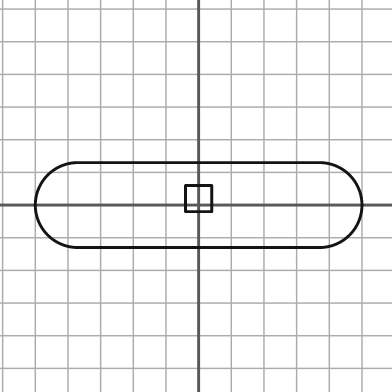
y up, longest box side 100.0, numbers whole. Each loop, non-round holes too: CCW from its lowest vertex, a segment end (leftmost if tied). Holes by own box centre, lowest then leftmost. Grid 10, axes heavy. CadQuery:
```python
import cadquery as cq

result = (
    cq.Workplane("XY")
    .moveTo(-37.0, -13.0)
    .lineTo(37.0, -13.0)
    .threePointArc((50.0, 0.0), (37.0, 13.0))
    .lineTo(-37.0, 13.0)
    .threePointArc((-50.0, 0.0), (-37.0, -13.0))
    .close()
    .moveTo(-4.0, -2.0)
    .lineTo(4.0, -2.0)
    .lineTo(4.0, 6.0)
    .lineTo(-4.0, 6.0)
    .close()
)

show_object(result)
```